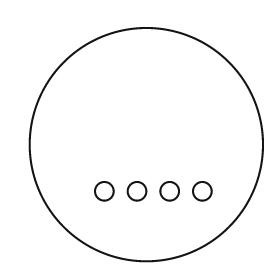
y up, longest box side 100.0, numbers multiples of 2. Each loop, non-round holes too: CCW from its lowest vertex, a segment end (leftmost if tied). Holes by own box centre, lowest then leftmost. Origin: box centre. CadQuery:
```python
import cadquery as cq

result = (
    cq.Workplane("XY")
    .moveTo(0.0, 0.0)
    .circle(50.0)
    .moveTo(-18.0, -20.0)
    .circle(4.0)
    .moveTo(-4.0, -20.0)
    .circle(4.0)
    .moveTo(10.0, -20.0)
    .circle(4.0)
    .moveTo(24.0, -20.0)
    .circle(4.0)
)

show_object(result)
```